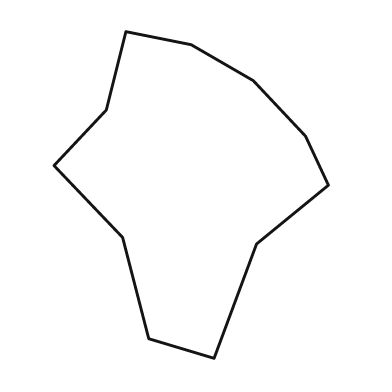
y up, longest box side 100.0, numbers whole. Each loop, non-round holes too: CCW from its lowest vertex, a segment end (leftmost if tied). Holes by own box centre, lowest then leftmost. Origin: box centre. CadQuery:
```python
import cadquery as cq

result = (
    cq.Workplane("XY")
    .moveTo(7.0, -50.0)
    .lineTo(20.0, -15.0)
    .lineTo(42.0, 3.0)
    .lineTo(35.0, 18.0)
    .lineTo(19.0, 35.0)
    .lineTo(0.0, 46.0)
    .lineTo(-20.0, 50.0)
    .lineTo(-26.0, 26.0)
    .lineTo(-42.0, 9.0)
    .lineTo(-21.0, -13.0)
    .lineTo(-13.0, -44.0)
    .close()
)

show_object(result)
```